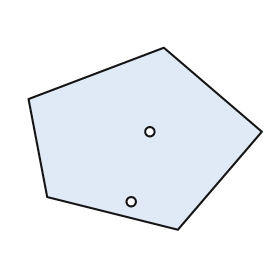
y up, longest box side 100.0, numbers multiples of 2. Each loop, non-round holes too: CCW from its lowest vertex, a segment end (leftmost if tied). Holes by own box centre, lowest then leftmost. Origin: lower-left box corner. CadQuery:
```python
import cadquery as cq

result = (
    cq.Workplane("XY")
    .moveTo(64.0, 0.0)
    .lineTo(100.0, 42.0)
    .lineTo(58.0, 78.0)
    .lineTo(0.0, 56.0)
    .lineTo(8.0, 14.0)
    .close()
    .moveTo(44.0, 12.0)
    .circle(2.0)
    .moveTo(52.0, 42.0)
    .circle(2.0)
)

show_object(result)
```